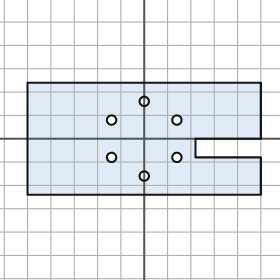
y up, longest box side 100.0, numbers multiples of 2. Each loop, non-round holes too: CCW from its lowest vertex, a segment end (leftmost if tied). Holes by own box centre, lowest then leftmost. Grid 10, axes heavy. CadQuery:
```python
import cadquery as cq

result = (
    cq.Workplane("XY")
    .moveTo(-50.0, -24.0)
    .lineTo(50.0, -24.0)
    .lineTo(50.0, -8.0)
    .lineTo(22.0, -8.0)
    .lineTo(22.0, 0.0)
    .lineTo(50.0, 0.0)
    .lineTo(50.0, 24.0)
    .lineTo(-50.0, 24.0)
    .close()
    .moveTo(0.0, -16.0)
    .circle(2.0)
    .moveTo(-14.0, -8.0)
    .circle(2.0)
    .moveTo(14.0, -8.0)
    .circle(2.0)
    .moveTo(-14.0, 8.0)
    .circle(2.0)
    .moveTo(14.0, 8.0)
    .circle(2.0)
    .moveTo(0.0, 16.0)
    .circle(2.0)
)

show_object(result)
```